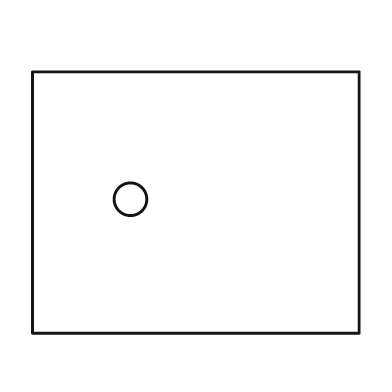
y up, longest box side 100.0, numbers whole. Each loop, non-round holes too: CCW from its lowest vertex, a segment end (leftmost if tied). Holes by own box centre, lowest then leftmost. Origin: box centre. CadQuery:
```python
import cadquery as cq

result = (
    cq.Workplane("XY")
    .moveTo(-50.0, -40.0)
    .lineTo(50.0, -40.0)
    .lineTo(50.0, 40.0)
    .lineTo(-50.0, 40.0)
    .close()
    .moveTo(-20.0, 1.0)
    .circle(5.0)
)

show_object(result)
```